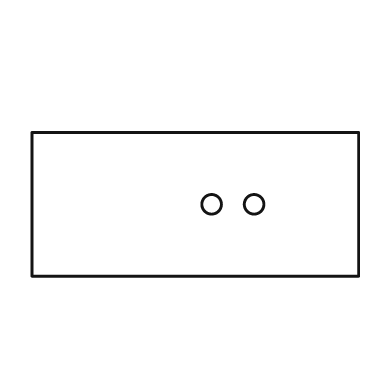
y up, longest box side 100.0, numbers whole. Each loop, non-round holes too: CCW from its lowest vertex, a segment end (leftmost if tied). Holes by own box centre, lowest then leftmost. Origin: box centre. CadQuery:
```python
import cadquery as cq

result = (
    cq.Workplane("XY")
    .moveTo(-50.0, -22.0)
    .lineTo(50.0, -22.0)
    .lineTo(50.0, 22.0)
    .lineTo(-50.0, 22.0)
    .close()
    .moveTo(5.0, 0.0)
    .circle(3.0)
    .moveTo(18.0, 0.0)
    .circle(3.0)
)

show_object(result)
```